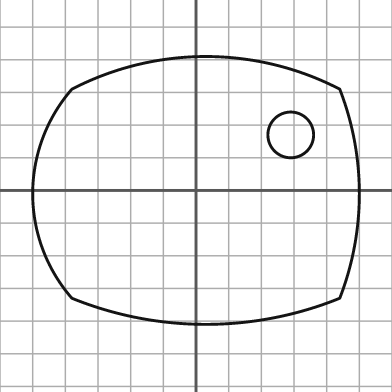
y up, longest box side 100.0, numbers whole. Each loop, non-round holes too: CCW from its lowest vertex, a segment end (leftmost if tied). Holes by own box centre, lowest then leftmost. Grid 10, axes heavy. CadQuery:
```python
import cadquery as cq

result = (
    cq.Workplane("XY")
    .moveTo(-38.0, -33.0)
    .threePointArc((3.0, -41.0), (44.0, -33.0))
    .threePointArc((50.0, -1.0), (44.0, 31.0))
    .threePointArc((3.0, 41.0), (-38.0, 31.0))
    .threePointArc((-50.0, -1.0), (-38.0, -33.0))
    .close()
    .moveTo(29.0, 17.0)
    .circle(7.0)
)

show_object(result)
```